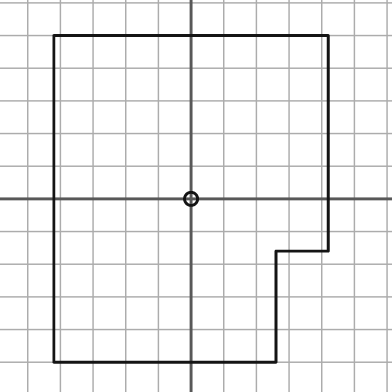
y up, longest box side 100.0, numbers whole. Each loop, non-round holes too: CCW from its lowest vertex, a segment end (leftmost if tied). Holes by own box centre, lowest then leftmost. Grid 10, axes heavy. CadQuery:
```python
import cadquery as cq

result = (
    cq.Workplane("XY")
    .moveTo(-42.0, -50.0)
    .lineTo(26.0, -50.0)
    .lineTo(26.0, -16.0)
    .lineTo(42.0, -16.0)
    .lineTo(42.0, 50.0)
    .lineTo(-42.0, 50.0)
    .close()
    .moveTo(0.0, 0.0)
    .circle(2.0)
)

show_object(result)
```